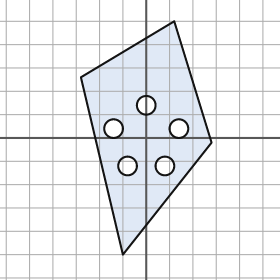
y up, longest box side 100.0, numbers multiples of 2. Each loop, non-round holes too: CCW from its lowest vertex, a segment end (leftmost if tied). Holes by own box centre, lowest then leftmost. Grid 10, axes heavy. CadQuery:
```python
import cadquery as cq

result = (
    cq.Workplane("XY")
    .moveTo(-10.0, -50.0)
    .lineTo(28.0, -2.0)
    .lineTo(12.0, 50.0)
    .lineTo(-28.0, 26.0)
    .close()
    .moveTo(-8.0, -12.0)
    .circle(4.0)
    .moveTo(8.0, -12.0)
    .circle(4.0)
    .moveTo(-14.0, 4.0)
    .circle(4.0)
    .moveTo(14.0, 4.0)
    .circle(4.0)
    .moveTo(0.0, 14.0)
    .circle(4.0)
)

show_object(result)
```